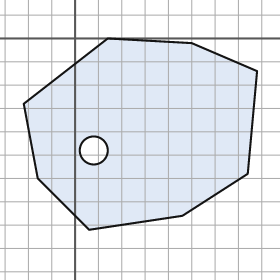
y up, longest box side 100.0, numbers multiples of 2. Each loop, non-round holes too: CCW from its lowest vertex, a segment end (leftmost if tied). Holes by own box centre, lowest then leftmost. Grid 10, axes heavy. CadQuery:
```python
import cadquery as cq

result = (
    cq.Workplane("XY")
    .moveTo(6.0, -82.0)
    .lineTo(46.0, -76.0)
    .lineTo(74.0, -58.0)
    .lineTo(78.0, -14.0)
    .lineTo(50.0, -2.0)
    .lineTo(14.0, 0.0)
    .lineTo(-22.0, -28.0)
    .lineTo(-16.0, -60.0)
    .close()
    .moveTo(8.0, -48.0)
    .circle(6.0)
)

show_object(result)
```